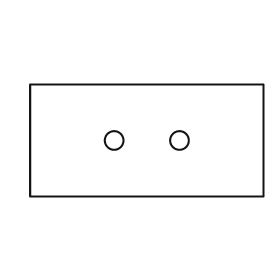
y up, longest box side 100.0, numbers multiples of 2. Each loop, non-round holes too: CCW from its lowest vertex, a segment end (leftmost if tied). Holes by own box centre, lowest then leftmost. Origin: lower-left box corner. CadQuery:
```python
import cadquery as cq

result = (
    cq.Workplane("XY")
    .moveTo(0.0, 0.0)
    .lineTo(100.0, 0.0)
    .lineTo(100.0, 48.0)
    .lineTo(0.0, 48.0)
    .close()
    .moveTo(36.0, 24.0)
    .circle(4.0)
    .moveTo(64.0, 24.0)
    .circle(4.0)
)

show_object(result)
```